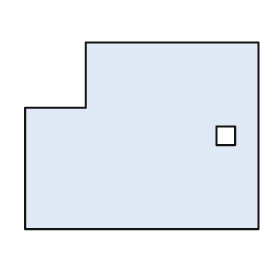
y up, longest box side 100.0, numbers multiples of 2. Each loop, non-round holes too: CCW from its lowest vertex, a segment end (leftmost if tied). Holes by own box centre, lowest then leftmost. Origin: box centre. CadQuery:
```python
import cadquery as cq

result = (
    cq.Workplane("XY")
    .moveTo(-50.0, -40.0)
    .lineTo(50.0, -40.0)
    .lineTo(50.0, 40.0)
    .lineTo(-24.0, 40.0)
    .lineTo(-24.0, 12.0)
    .lineTo(-50.0, 12.0)
    .close()
    .moveTo(32.0, -4.0)
    .lineTo(40.0, -4.0)
    .lineTo(40.0, 4.0)
    .lineTo(32.0, 4.0)
    .close()
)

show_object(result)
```